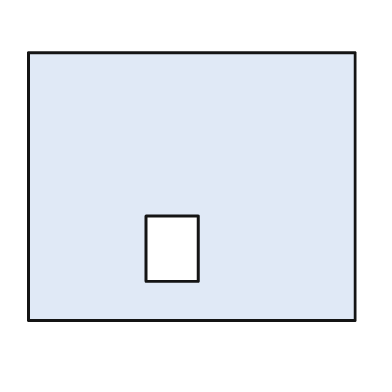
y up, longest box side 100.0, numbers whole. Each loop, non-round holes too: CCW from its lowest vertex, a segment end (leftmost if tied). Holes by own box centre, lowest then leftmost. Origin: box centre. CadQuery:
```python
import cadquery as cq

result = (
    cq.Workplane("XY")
    .moveTo(-50.0, -41.0)
    .lineTo(50.0, -41.0)
    .lineTo(50.0, 41.0)
    .lineTo(-50.0, 41.0)
    .close()
    .moveTo(-14.0, -29.0)
    .lineTo(2.0, -29.0)
    .lineTo(2.0, -9.0)
    .lineTo(-14.0, -9.0)
    .close()
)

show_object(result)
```